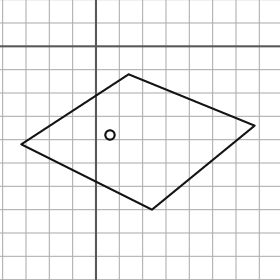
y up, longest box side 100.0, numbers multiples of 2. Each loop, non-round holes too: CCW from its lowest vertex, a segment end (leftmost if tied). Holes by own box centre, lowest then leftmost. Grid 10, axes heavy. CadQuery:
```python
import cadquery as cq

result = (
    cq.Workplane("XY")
    .moveTo(24.0, -70.0)
    .lineTo(68.0, -34.0)
    .lineTo(14.0, -12.0)
    .lineTo(-32.0, -42.0)
    .close()
    .moveTo(6.0, -38.0)
    .circle(2.0)
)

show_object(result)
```